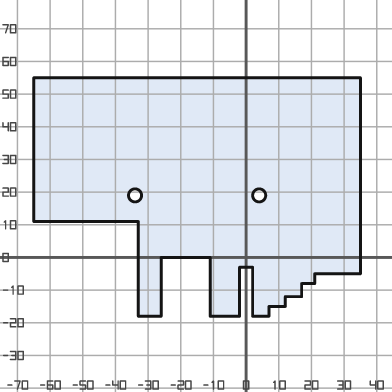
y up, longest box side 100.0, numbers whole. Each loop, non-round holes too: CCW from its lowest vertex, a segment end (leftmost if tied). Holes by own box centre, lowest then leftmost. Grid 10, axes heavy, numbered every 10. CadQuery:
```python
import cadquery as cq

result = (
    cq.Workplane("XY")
    .moveTo(-33.0, -18.0)
    .lineTo(-26.0, -18.0)
    .lineTo(-26.0, 0.0)
    .lineTo(-11.0, 0.0)
    .lineTo(-11.0, -18.0)
    .lineTo(-2.0, -18.0)
    .lineTo(-2.0, -3.0)
    .lineTo(2.0, -3.0)
    .lineTo(2.0, -18.0)
    .lineTo(7.0, -18.0)
    .lineTo(7.0, -15.0)
    .lineTo(12.0, -15.0)
    .lineTo(12.0, -12.0)
    .lineTo(17.0, -12.0)
    .lineTo(17.0, -8.0)
    .lineTo(21.0, -8.0)
    .lineTo(21.0, -5.0)
    .lineTo(35.0, -5.0)
    .lineTo(35.0, 55.0)
    .lineTo(-65.0, 55.0)
    .lineTo(-65.0, 11.0)
    .lineTo(-33.0, 11.0)
    .close()
    .moveTo(-34.0, 19.0)
    .circle(2.0)
    .moveTo(4.0, 19.0)
    .circle(2.0)
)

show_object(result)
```